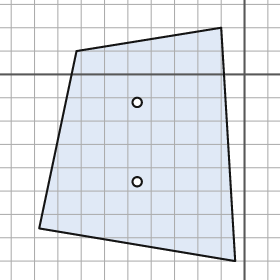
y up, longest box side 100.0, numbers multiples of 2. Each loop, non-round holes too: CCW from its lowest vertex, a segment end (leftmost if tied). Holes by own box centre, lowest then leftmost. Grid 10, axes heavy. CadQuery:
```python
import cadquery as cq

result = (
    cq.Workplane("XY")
    .moveTo(-4.0, -80.0)
    .lineTo(-10.0, 20.0)
    .lineTo(-72.0, 10.0)
    .lineTo(-88.0, -66.0)
    .close()
    .moveTo(-46.0, -46.0)
    .circle(2.0)
    .moveTo(-46.0, -12.0)
    .circle(2.0)
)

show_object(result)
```